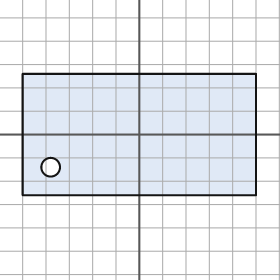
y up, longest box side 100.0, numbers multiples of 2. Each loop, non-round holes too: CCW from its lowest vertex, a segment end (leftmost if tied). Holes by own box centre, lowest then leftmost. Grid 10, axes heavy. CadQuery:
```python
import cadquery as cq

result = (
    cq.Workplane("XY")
    .moveTo(-50.0, -26.0)
    .lineTo(50.0, -26.0)
    .lineTo(50.0, 26.0)
    .lineTo(-50.0, 26.0)
    .close()
    .moveTo(-38.0, -14.0)
    .circle(4.0)
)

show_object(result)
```